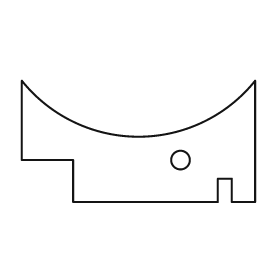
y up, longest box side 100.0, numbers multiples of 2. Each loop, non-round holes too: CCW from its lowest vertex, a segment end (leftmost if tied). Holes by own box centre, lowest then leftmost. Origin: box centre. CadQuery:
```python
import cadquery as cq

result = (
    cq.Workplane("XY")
    .moveTo(-28.0, -26.0)
    .lineTo(34.0, -26.0)
    .lineTo(34.0, -16.0)
    .lineTo(40.0, -16.0)
    .lineTo(40.0, -26.0)
    .lineTo(50.0, -26.0)
    .lineTo(50.0, 26.0)
    .threePointArc((0.0, 2.0), (-50.0, 26.0))
    .lineTo(-50.0, -8.0)
    .lineTo(-28.0, -8.0)
    .close()
    .moveTo(18.0, -8.0)
    .circle(4.0)
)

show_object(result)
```